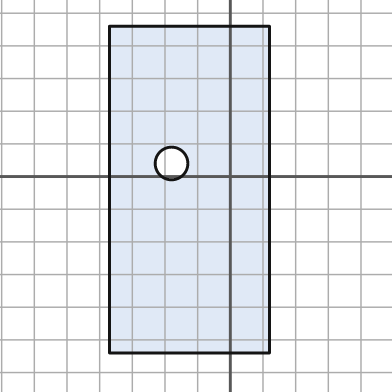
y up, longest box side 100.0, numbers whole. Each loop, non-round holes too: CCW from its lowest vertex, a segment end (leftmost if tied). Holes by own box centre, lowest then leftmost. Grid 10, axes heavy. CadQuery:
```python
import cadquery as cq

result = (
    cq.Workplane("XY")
    .moveTo(-37.0, -54.0)
    .lineTo(12.0, -54.0)
    .lineTo(12.0, 46.0)
    .lineTo(-37.0, 46.0)
    .close()
    .moveTo(-18.0, 4.0)
    .circle(5.0)
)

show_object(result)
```